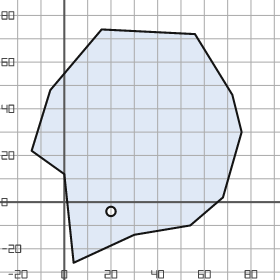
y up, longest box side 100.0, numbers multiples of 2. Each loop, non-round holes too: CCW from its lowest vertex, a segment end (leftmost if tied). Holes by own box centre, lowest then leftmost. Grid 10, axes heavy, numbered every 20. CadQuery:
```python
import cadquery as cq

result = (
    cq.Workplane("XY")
    .moveTo(4.0, -26.0)
    .lineTo(30.0, -14.0)
    .lineTo(54.0, -10.0)
    .lineTo(68.0, 2.0)
    .lineTo(76.0, 30.0)
    .lineTo(72.0, 46.0)
    .lineTo(56.0, 72.0)
    .lineTo(16.0, 74.0)
    .lineTo(-6.0, 48.0)
    .lineTo(-14.0, 22.0)
    .lineTo(0.0, 12.0)
    .close()
    .moveTo(20.0, -4.0)
    .circle(2.0)
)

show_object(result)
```